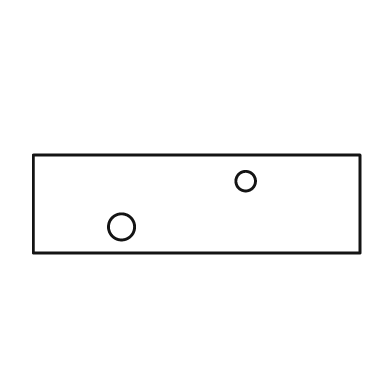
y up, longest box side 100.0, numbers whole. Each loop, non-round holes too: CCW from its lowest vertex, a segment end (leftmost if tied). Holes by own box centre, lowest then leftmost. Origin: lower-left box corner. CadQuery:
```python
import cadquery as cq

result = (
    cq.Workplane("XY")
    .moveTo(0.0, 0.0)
    .lineTo(100.0, 0.0)
    .lineTo(100.0, 30.0)
    .lineTo(0.0, 30.0)
    .close()
    .moveTo(27.0, 8.0)
    .circle(4.0)
    .moveTo(65.0, 22.0)
    .circle(3.0)
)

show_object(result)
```